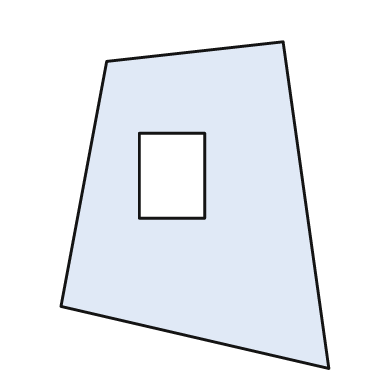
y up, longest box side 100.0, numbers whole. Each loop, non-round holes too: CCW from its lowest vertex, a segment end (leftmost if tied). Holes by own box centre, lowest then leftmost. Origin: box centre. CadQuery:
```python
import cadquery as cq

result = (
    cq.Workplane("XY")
    .moveTo(41.0, -50.0)
    .lineTo(27.0, 50.0)
    .lineTo(-27.0, 44.0)
    .lineTo(-41.0, -31.0)
    .close()
    .moveTo(-17.0, -4.0)
    .lineTo(3.0, -4.0)
    .lineTo(3.0, 22.0)
    .lineTo(-17.0, 22.0)
    .close()
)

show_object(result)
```